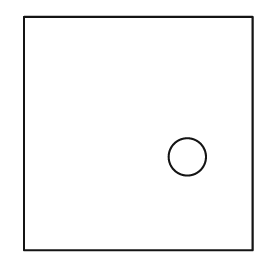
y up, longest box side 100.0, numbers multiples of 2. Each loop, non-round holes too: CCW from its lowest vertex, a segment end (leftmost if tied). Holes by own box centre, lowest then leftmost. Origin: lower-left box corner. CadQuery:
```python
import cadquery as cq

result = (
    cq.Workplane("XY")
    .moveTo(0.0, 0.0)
    .lineTo(98.0, 0.0)
    .lineTo(98.0, 100.0)
    .lineTo(0.0, 100.0)
    .close()
    .moveTo(70.0, 40.0)
    .circle(8.0)
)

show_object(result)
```